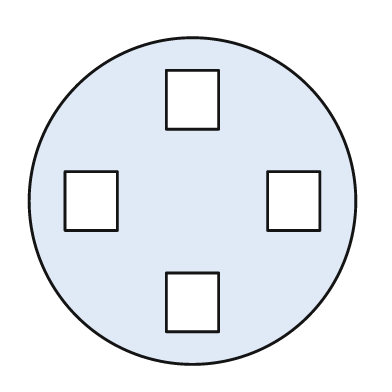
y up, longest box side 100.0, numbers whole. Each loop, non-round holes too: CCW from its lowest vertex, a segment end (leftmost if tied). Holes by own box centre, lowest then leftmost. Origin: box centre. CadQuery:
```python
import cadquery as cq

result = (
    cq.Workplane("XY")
    .moveTo(0.0, 0.0)
    .circle(50.0)
    .moveTo(-8.0, -40.0)
    .lineTo(8.0, -40.0)
    .lineTo(8.0, -22.0)
    .lineTo(-8.0, -22.0)
    .close()
    .moveTo(-39.0, -9.0)
    .lineTo(-23.0, -9.0)
    .lineTo(-23.0, 9.0)
    .lineTo(-39.0, 9.0)
    .close()
    .moveTo(23.0, -9.0)
    .lineTo(39.0, -9.0)
    .lineTo(39.0, 9.0)
    .lineTo(23.0, 9.0)
    .close()
    .moveTo(-8.0, 22.0)
    .lineTo(8.0, 22.0)
    .lineTo(8.0, 40.0)
    .lineTo(-8.0, 40.0)
    .close()
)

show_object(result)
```